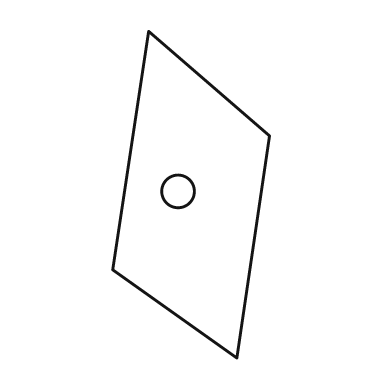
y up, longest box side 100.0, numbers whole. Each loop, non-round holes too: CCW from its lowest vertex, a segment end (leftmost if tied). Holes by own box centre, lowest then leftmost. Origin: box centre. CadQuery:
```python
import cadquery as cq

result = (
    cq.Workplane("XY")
    .moveTo(14.0, -50.0)
    .lineTo(24.0, 18.0)
    .lineTo(-13.0, 50.0)
    .lineTo(-24.0, -23.0)
    .close()
    .moveTo(-4.0, 1.0)
    .circle(5.0)
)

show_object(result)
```